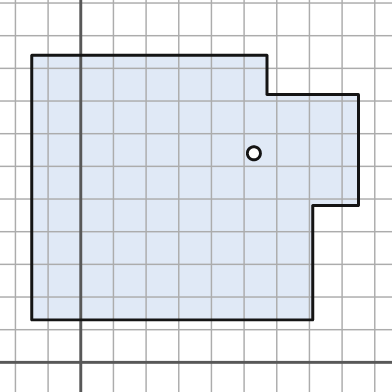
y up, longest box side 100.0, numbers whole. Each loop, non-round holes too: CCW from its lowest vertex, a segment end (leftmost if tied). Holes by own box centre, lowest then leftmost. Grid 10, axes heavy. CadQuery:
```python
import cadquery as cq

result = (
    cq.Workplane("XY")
    .moveTo(-15.0, 13.0)
    .lineTo(71.0, 13.0)
    .lineTo(71.0, 48.0)
    .lineTo(85.0, 48.0)
    .lineTo(85.0, 82.0)
    .lineTo(57.0, 82.0)
    .lineTo(57.0, 94.0)
    .lineTo(-15.0, 94.0)
    .close()
    .moveTo(53.0, 64.0)
    .circle(2.0)
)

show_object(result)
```